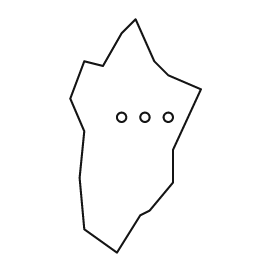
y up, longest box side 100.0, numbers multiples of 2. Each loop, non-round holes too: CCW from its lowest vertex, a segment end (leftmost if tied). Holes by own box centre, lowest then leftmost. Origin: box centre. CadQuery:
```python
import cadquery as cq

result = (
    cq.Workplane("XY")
    .moveTo(-8.0, -50.0)
    .lineTo(2.0, -34.0)
    .lineTo(6.0, -32.0)
    .lineTo(16.0, -20.0)
    .lineTo(16.0, -6.0)
    .lineTo(28.0, 20.0)
    .lineTo(14.0, 26.0)
    .lineTo(8.0, 32.0)
    .lineTo(0.0, 50.0)
    .lineTo(-6.0, 44.0)
    .lineTo(-14.0, 30.0)
    .lineTo(-22.0, 32.0)
    .lineTo(-28.0, 16.0)
    .lineTo(-22.0, 2.0)
    .lineTo(-24.0, -18.0)
    .lineTo(-22.0, -40.0)
    .close()
    .moveTo(-6.0, 8.0)
    .circle(2.0)
    .moveTo(4.0, 8.0)
    .circle(2.0)
    .moveTo(14.0, 8.0)
    .circle(2.0)
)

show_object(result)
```